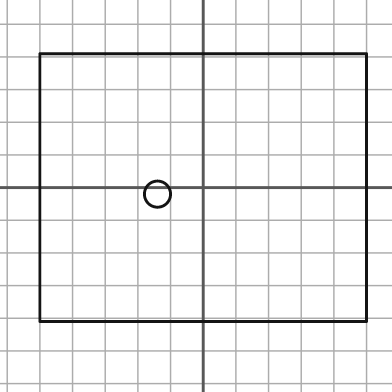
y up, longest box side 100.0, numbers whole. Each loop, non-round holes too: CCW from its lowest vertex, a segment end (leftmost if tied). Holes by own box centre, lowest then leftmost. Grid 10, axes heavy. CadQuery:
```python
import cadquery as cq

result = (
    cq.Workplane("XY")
    .moveTo(-50.0, -41.0)
    .lineTo(50.0, -41.0)
    .lineTo(50.0, 41.0)
    .lineTo(-50.0, 41.0)
    .close()
    .moveTo(-14.0, -2.0)
    .circle(4.0)
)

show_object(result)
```